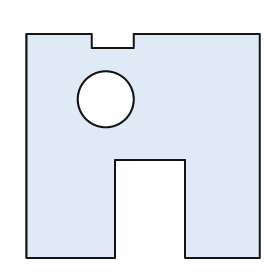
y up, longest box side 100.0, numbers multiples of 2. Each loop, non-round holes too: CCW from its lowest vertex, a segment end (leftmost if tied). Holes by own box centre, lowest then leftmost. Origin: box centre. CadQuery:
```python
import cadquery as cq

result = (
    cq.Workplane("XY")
    .moveTo(-50.0, -48.0)
    .lineTo(-12.0, -48.0)
    .lineTo(-12.0, -6.0)
    .lineTo(18.0, -6.0)
    .lineTo(18.0, -48.0)
    .lineTo(50.0, -48.0)
    .lineTo(50.0, 48.0)
    .lineTo(-4.0, 48.0)
    .lineTo(-4.0, 42.0)
    .lineTo(-22.0, 42.0)
    .lineTo(-22.0, 48.0)
    .lineTo(-50.0, 48.0)
    .close()
    .moveTo(-16.0, 20.0)
    .circle(12.0)
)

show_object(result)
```